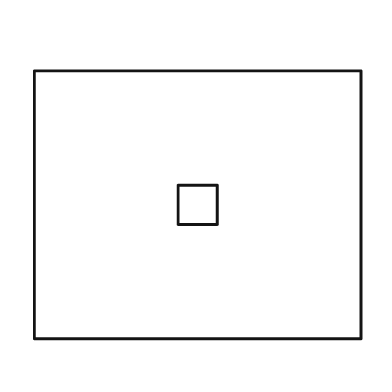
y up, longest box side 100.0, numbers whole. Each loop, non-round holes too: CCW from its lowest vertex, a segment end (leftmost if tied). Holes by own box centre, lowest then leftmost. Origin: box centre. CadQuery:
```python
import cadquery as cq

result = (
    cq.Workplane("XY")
    .moveTo(-50.0, -41.0)
    .lineTo(50.0, -41.0)
    .lineTo(50.0, 41.0)
    .lineTo(-50.0, 41.0)
    .close()
    .moveTo(-6.0, -6.0)
    .lineTo(6.0, -6.0)
    .lineTo(6.0, 6.0)
    .lineTo(-6.0, 6.0)
    .close()
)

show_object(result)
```